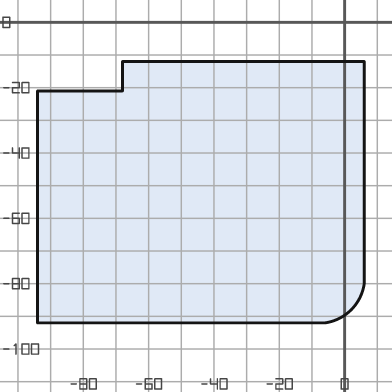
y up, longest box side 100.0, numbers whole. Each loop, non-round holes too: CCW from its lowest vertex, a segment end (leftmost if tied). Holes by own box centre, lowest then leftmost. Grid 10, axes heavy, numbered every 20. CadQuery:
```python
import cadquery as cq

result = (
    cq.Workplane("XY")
    .moveTo(-94.0, -92.0)
    .lineTo(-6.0, -92.0)
    .threePointArc((2.0, -88.0), (6.0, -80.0))
    .lineTo(6.0, -12.0)
    .lineTo(-68.0, -12.0)
    .lineTo(-68.0, -21.0)
    .lineTo(-94.0, -21.0)
    .close()
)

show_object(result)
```